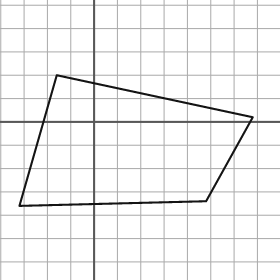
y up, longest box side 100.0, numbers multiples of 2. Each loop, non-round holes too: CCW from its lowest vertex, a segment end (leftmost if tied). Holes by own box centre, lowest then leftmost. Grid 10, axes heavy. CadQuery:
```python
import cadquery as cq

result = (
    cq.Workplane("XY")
    .moveTo(-32.0, -36.0)
    .lineTo(48.0, -34.0)
    .lineTo(68.0, 2.0)
    .lineTo(-16.0, 20.0)
    .close()
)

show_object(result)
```